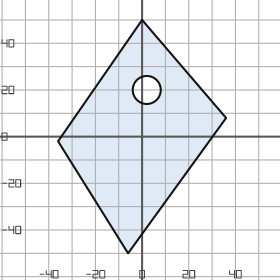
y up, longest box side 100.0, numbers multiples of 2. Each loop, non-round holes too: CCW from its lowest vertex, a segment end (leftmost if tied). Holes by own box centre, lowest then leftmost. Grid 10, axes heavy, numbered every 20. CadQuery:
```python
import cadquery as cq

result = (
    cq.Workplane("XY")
    .moveTo(-6.0, -50.0)
    .lineTo(36.0, 8.0)
    .lineTo(0.0, 50.0)
    .lineTo(-36.0, -2.0)
    .close()
    .moveTo(2.0, 20.0)
    .circle(6.0)
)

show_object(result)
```